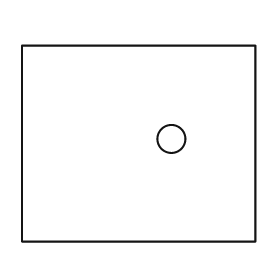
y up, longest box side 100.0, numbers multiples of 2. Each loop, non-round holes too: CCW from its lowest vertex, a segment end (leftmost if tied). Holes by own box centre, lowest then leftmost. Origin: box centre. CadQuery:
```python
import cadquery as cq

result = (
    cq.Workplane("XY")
    .moveTo(-50.0, -42.0)
    .lineTo(50.0, -42.0)
    .lineTo(50.0, 42.0)
    .lineTo(-50.0, 42.0)
    .close()
    .moveTo(14.0, 2.0)
    .circle(6.0)
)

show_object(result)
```